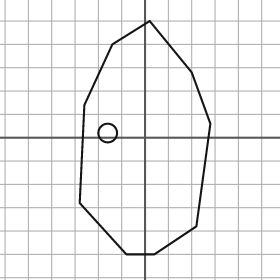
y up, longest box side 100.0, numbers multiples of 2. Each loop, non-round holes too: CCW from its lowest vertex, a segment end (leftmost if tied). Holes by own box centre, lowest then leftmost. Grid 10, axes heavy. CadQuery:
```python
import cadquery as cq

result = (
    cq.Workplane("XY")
    .moveTo(-8.0, -50.0)
    .lineTo(4.0, -50.0)
    .lineTo(22.0, -38.0)
    .lineTo(28.0, 6.0)
    .lineTo(20.0, 28.0)
    .lineTo(2.0, 50.0)
    .lineTo(-14.0, 40.0)
    .lineTo(-26.0, 14.0)
    .lineTo(-28.0, -28.0)
    .close()
    .moveTo(-16.0, 2.0)
    .circle(4.0)
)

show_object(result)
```